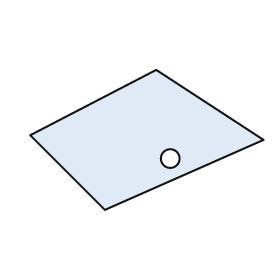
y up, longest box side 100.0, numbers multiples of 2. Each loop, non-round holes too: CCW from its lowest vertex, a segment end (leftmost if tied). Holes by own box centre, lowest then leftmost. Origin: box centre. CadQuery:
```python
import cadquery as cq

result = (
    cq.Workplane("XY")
    .moveTo(-18.0, -30.0)
    .lineTo(50.0, 0.0)
    .lineTo(4.0, 30.0)
    .lineTo(-50.0, 2.0)
    .close()
    .moveTo(10.0, -8.0)
    .circle(4.0)
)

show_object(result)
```